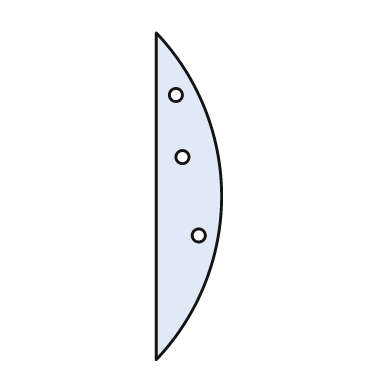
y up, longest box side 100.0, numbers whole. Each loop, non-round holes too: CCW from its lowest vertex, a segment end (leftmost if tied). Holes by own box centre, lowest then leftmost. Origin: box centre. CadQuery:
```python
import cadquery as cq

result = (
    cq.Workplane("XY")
    .moveTo(-10.0, -50.0)
    .threePointArc((10.0, 0.0), (-10.0, 50.0))
    .close()
    .moveTo(3.0, -12.0)
    .circle(2.0)
    .moveTo(-2.0, 12.0)
    .circle(2.0)
    .moveTo(-4.0, 31.0)
    .circle(2.0)
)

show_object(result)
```